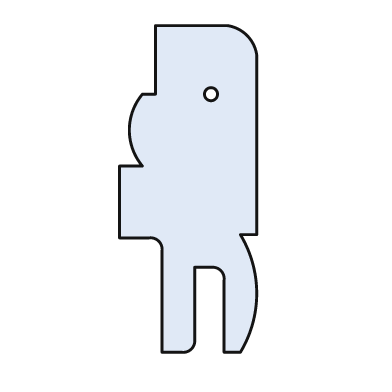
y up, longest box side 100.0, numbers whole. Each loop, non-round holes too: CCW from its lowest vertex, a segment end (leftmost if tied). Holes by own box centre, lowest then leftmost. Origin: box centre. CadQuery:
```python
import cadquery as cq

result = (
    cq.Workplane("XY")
    .moveTo(-8.0, -50.0)
    .lineTo(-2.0, -50.0)
    .threePointArc((1.0, -49.0), (2.0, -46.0))
    .lineTo(2.0, -24.0)
    .lineTo(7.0, -24.0)
    .threePointArc((10.0, -25.0), (11.0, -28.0))
    .lineTo(11.0, -50.0)
    .lineTo(16.0, -50.0)
    .threePointArc((21.0, -32.0), (16.0, -14.0))
    .lineTo(21.0, -14.0)
    .lineTo(21.0, 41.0)
    .threePointArc((18.0, 47.0), (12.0, 50.0))
    .lineTo(-10.0, 50.0)
    .lineTo(-10.0, 29.0)
    .lineTo(-14.0, 29.0)
    .threePointArc((-18.0, 18.0), (-14.0, 7.0))
    .lineTo(-21.0, 7.0)
    .lineTo(-21.0, -15.0)
    .lineTo(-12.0, -15.0)
    .threePointArc((-9.0, -16.0), (-8.0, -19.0))
    .close()
    .moveTo(7.0, 29.0)
    .circle(2.0)
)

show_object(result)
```